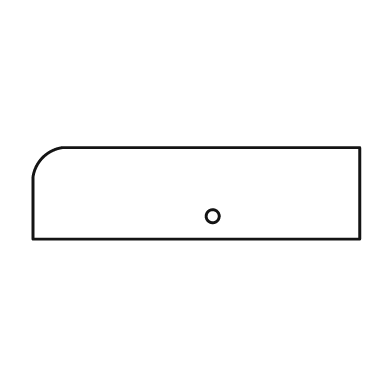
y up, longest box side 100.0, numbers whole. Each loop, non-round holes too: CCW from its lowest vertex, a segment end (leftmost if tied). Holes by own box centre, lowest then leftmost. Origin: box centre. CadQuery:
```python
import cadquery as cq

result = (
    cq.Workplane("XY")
    .moveTo(-50.0, -14.0)
    .lineTo(50.0, -14.0)
    .lineTo(50.0, 14.0)
    .lineTo(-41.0, 14.0)
    .threePointArc((-47.0, 11.0), (-50.0, 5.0))
    .close()
    .moveTo(5.0, -7.0)
    .circle(2.0)
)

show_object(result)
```